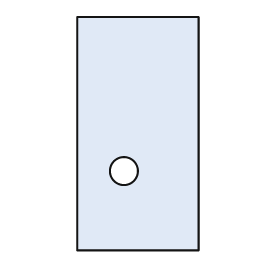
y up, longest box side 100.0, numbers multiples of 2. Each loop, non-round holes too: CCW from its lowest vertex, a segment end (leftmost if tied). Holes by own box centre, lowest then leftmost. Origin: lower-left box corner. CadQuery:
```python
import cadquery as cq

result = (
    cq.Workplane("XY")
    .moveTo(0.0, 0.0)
    .lineTo(52.0, 0.0)
    .lineTo(52.0, 100.0)
    .lineTo(0.0, 100.0)
    .close()
    .moveTo(20.0, 34.0)
    .circle(6.0)
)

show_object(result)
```